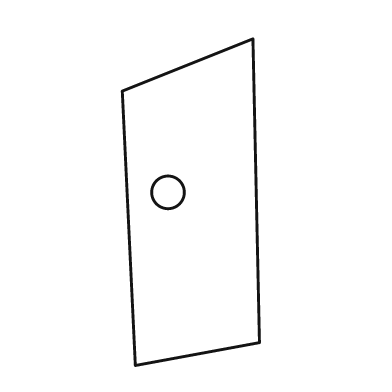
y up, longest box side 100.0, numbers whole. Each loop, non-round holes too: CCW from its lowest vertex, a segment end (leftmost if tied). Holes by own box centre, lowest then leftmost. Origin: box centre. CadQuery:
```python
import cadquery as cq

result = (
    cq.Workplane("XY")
    .moveTo(-17.0, -50.0)
    .lineTo(21.0, -43.0)
    .lineTo(19.0, 50.0)
    .lineTo(-21.0, 34.0)
    .close()
    .moveTo(-7.0, 3.0)
    .circle(5.0)
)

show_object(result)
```